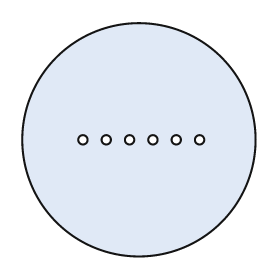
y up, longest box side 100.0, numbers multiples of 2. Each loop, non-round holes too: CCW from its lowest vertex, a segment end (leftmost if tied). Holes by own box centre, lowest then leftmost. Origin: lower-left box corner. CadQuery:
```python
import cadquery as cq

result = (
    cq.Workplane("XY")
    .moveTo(50.0, 50.0)
    .circle(50.0)
    .moveTo(26.0, 50.0)
    .circle(2.0)
    .moveTo(36.0, 50.0)
    .circle(2.0)
    .moveTo(46.0, 50.0)
    .circle(2.0)
    .moveTo(56.0, 50.0)
    .circle(2.0)
    .moveTo(66.0, 50.0)
    .circle(2.0)
    .moveTo(76.0, 50.0)
    .circle(2.0)
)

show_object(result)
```